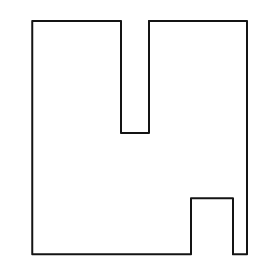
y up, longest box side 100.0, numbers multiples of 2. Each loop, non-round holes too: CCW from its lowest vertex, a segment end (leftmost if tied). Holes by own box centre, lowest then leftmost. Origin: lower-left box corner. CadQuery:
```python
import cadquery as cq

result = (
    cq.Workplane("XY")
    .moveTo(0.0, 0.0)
    .lineTo(68.0, 0.0)
    .lineTo(68.0, 24.0)
    .lineTo(86.0, 24.0)
    .lineTo(86.0, 0.0)
    .lineTo(92.0, 0.0)
    .lineTo(92.0, 100.0)
    .lineTo(50.0, 100.0)
    .lineTo(50.0, 52.0)
    .lineTo(38.0, 52.0)
    .lineTo(38.0, 100.0)
    .lineTo(0.0, 100.0)
    .close()
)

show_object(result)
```